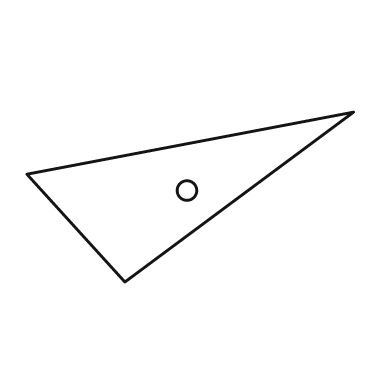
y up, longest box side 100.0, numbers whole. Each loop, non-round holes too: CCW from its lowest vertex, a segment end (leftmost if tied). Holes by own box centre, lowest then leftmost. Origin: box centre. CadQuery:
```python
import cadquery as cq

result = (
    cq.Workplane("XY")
    .moveTo(-20.0, -26.0)
    .lineTo(50.0, 26.0)
    .lineTo(-50.0, 7.0)
    .close()
    .moveTo(-1.0, 2.0)
    .circle(3.0)
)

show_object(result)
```